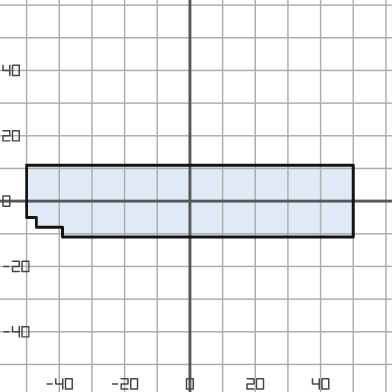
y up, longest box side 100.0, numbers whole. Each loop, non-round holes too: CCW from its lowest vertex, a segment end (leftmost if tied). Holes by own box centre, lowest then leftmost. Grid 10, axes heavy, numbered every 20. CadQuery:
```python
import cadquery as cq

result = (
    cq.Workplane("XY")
    .moveTo(-39.0, -11.0)
    .lineTo(50.0, -11.0)
    .lineTo(50.0, 11.0)
    .lineTo(-50.0, 11.0)
    .lineTo(-50.0, -5.0)
    .lineTo(-47.0, -5.0)
    .lineTo(-47.0, -8.0)
    .lineTo(-39.0, -8.0)
    .close()
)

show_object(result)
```